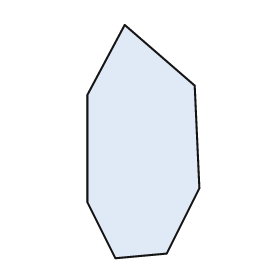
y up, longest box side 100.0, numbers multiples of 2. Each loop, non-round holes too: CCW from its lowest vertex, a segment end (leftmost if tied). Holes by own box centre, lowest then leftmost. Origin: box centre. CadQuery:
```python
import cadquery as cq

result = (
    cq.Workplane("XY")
    .moveTo(-12.0, -50.0)
    .lineTo(10.0, -48.0)
    .lineTo(24.0, -20.0)
    .lineTo(22.0, 24.0)
    .lineTo(-8.0, 50.0)
    .lineTo(-24.0, 20.0)
    .lineTo(-24.0, -26.0)
    .close()
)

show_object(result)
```